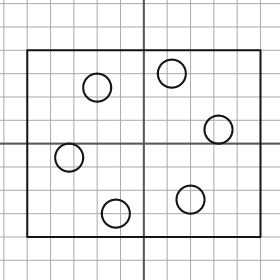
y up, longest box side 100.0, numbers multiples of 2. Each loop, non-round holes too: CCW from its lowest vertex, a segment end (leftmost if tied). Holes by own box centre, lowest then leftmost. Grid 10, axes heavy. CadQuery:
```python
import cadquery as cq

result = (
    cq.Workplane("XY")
    .moveTo(-50.0, -40.0)
    .lineTo(50.0, -40.0)
    .lineTo(50.0, 40.0)
    .lineTo(-50.0, 40.0)
    .close()
    .moveTo(-12.0, -30.0)
    .circle(6.0)
    .moveTo(20.0, -24.0)
    .circle(6.0)
    .moveTo(-32.0, -6.0)
    .circle(6.0)
    .moveTo(32.0, 6.0)
    .circle(6.0)
    .moveTo(-20.0, 24.0)
    .circle(6.0)
    .moveTo(12.0, 30.0)
    .circle(6.0)
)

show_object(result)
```